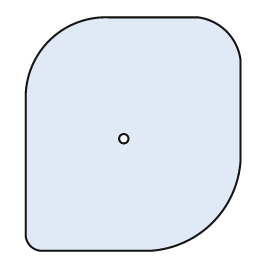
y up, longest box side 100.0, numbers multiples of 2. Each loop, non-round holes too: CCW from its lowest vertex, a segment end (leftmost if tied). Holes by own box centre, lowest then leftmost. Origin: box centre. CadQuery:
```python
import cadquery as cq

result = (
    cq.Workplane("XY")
    .moveTo(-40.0, -50.0)
    .lineTo(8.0, -50.0)
    .threePointArc((34.0, -38.0), (46.0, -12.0))
    .lineTo(46.0, 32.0)
    .threePointArc((40.0, 44.0), (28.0, 50.0))
    .lineTo(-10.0, 50.0)
    .threePointArc((-36.0, 40.0), (-46.0, 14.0))
    .lineTo(-46.0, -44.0)
    .threePointArc((-44.0, -48.0), (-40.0, -50.0))
    .close()
    .moveTo(-4.0, -2.0)
    .circle(2.0)
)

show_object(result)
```